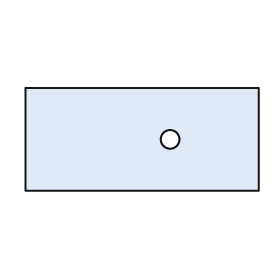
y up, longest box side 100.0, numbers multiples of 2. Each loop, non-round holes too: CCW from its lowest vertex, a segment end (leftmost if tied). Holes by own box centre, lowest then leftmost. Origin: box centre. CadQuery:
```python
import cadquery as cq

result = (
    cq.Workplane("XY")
    .moveTo(-50.0, -22.0)
    .lineTo(50.0, -22.0)
    .lineTo(50.0, 22.0)
    .lineTo(-50.0, 22.0)
    .close()
    .moveTo(12.0, 0.0)
    .circle(4.0)
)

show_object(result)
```